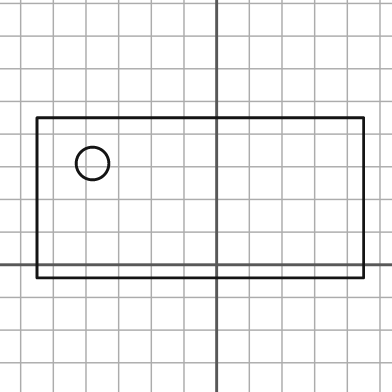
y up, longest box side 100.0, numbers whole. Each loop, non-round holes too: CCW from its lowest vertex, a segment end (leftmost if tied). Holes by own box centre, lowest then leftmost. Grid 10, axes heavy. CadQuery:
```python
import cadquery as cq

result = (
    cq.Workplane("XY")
    .moveTo(-55.0, -4.0)
    .lineTo(45.0, -4.0)
    .lineTo(45.0, 45.0)
    .lineTo(-55.0, 45.0)
    .close()
    .moveTo(-38.0, 31.0)
    .circle(5.0)
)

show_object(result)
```